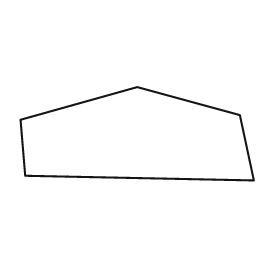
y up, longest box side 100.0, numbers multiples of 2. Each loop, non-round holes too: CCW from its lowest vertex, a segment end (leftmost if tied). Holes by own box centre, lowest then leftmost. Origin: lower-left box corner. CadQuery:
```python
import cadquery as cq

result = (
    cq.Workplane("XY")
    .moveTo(100.0, 0.0)
    .lineTo(94.0, 28.0)
    .lineTo(50.0, 40.0)
    .lineTo(0.0, 26.0)
    .lineTo(2.0, 2.0)
    .close()
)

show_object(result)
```